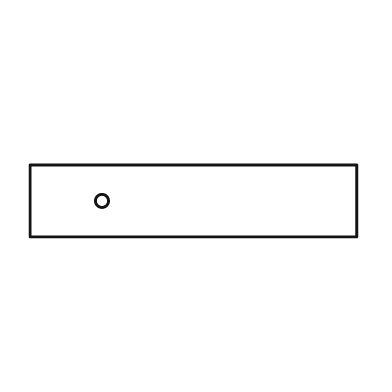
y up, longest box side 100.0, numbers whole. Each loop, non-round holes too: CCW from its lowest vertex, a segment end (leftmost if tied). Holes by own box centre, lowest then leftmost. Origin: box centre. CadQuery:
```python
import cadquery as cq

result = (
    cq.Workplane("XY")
    .moveTo(-50.0, -11.0)
    .lineTo(50.0, -11.0)
    .lineTo(50.0, 11.0)
    .lineTo(-50.0, 11.0)
    .close()
    .moveTo(-28.0, 0.0)
    .circle(2.0)
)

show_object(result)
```